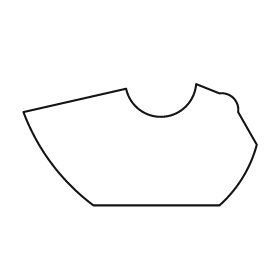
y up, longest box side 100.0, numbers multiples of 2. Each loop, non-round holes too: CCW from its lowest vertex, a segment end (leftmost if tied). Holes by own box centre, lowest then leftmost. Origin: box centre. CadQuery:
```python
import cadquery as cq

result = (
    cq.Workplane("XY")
    .moveTo(-20.0, -26.0)
    .lineTo(34.0, -26.0)
    .threePointArc((44.0, -14.0), (50.0, 0.0))
    .lineTo(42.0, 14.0)
    .threePointArc((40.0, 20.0), (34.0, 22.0))
    .lineTo(24.0, 26.0)
    .threePointArc((10.0, 12.0), (-6.0, 24.0))
    .lineTo(-50.0, 14.0)
    .threePointArc((-38.0, -8.0), (-20.0, -26.0))
    .close()
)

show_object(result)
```